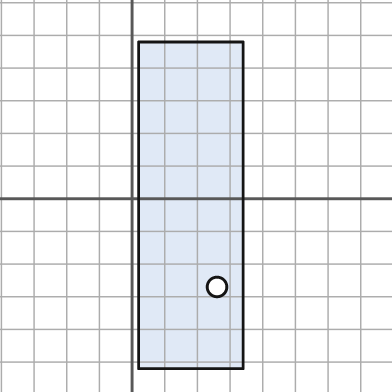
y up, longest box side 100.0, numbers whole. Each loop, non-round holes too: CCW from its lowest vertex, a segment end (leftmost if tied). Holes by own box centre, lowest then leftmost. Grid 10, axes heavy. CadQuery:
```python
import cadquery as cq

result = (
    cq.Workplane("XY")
    .moveTo(2.0, -52.0)
    .lineTo(34.0, -52.0)
    .lineTo(34.0, 48.0)
    .lineTo(2.0, 48.0)
    .close()
    .moveTo(26.0, -27.0)
    .circle(3.0)
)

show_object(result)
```